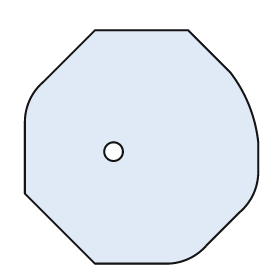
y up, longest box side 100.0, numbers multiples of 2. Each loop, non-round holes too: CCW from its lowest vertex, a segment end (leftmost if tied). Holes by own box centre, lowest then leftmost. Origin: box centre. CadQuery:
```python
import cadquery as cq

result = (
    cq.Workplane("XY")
    .moveTo(-20.0, -50.0)
    .lineTo(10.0, -50.0)
    .threePointArc((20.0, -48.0), (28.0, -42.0))
    .lineTo(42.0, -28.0)
    .threePointArc((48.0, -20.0), (50.0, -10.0))
    .lineTo(50.0, 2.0)
    .threePointArc((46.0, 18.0), (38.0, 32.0))
    .lineTo(20.0, 50.0)
    .lineTo(-20.0, 50.0)
    .lineTo(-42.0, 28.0)
    .threePointArc((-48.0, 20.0), (-50.0, 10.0))
    .lineTo(-50.0, -20.0)
    .close()
    .moveTo(-12.0, -2.0)
    .circle(4.0)
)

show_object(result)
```